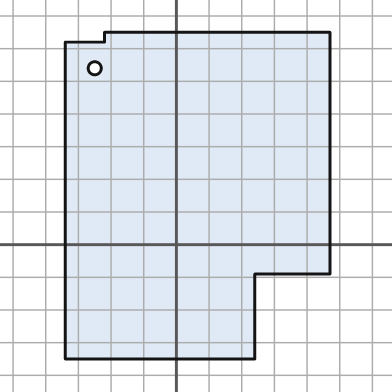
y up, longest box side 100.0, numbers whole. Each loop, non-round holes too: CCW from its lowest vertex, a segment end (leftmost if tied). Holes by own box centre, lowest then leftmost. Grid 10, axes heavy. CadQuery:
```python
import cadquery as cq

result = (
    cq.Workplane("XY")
    .moveTo(-34.0, -35.0)
    .lineTo(24.0, -35.0)
    .lineTo(24.0, -9.0)
    .lineTo(47.0, -9.0)
    .lineTo(47.0, 65.0)
    .lineTo(-22.0, 65.0)
    .lineTo(-22.0, 62.0)
    .lineTo(-34.0, 62.0)
    .close()
    .moveTo(-25.0, 54.0)
    .circle(2.0)
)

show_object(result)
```